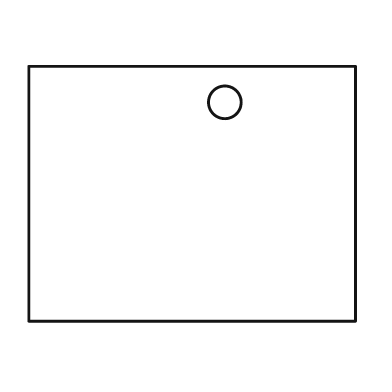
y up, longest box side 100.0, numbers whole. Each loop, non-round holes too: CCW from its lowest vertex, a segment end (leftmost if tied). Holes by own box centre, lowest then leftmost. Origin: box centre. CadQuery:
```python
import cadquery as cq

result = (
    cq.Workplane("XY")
    .moveTo(-50.0, -39.0)
    .lineTo(50.0, -39.0)
    .lineTo(50.0, 39.0)
    .lineTo(-50.0, 39.0)
    .close()
    .moveTo(10.0, 28.0)
    .circle(5.0)
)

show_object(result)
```